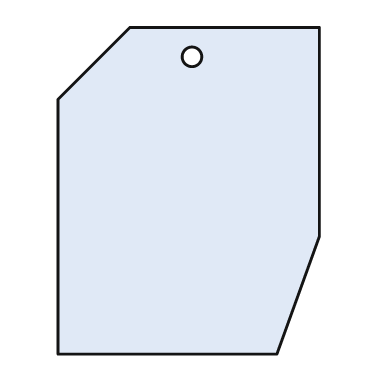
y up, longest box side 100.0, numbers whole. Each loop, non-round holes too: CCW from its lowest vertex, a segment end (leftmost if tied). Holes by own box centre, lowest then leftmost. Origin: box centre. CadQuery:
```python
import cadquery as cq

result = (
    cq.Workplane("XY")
    .moveTo(-40.0, -50.0)
    .lineTo(27.0, -50.0)
    .lineTo(40.0, -14.0)
    .lineTo(40.0, 50.0)
    .lineTo(-18.0, 50.0)
    .lineTo(-40.0, 28.0)
    .close()
    .moveTo(1.0, 41.0)
    .circle(3.0)
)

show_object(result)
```